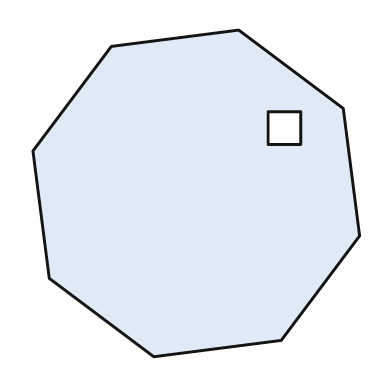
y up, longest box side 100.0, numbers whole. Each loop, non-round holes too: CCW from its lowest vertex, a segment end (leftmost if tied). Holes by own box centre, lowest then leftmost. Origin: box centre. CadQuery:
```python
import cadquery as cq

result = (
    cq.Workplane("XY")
    .moveTo(-13.0, -50.0)
    .lineTo(26.0, -45.0)
    .lineTo(50.0, -13.0)
    .lineTo(45.0, 26.0)
    .lineTo(13.0, 50.0)
    .lineTo(-26.0, 45.0)
    .lineTo(-50.0, 13.0)
    .lineTo(-45.0, -26.0)
    .close()
    .moveTo(22.0, 15.0)
    .lineTo(32.0, 15.0)
    .lineTo(32.0, 25.0)
    .lineTo(22.0, 25.0)
    .close()
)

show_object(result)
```